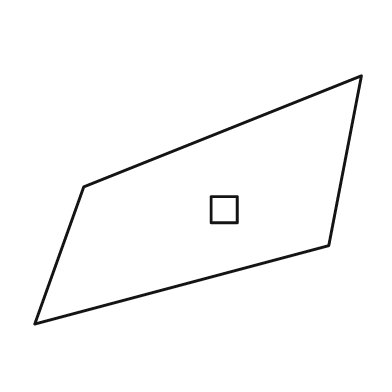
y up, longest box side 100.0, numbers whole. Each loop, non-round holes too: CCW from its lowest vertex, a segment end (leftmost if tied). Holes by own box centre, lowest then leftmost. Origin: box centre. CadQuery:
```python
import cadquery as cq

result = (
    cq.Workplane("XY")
    .moveTo(-50.0, -38.0)
    .lineTo(40.0, -14.0)
    .lineTo(50.0, 38.0)
    .lineTo(-35.0, 4.0)
    .close()
    .moveTo(4.0, -7.0)
    .lineTo(12.0, -7.0)
    .lineTo(12.0, 1.0)
    .lineTo(4.0, 1.0)
    .close()
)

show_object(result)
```